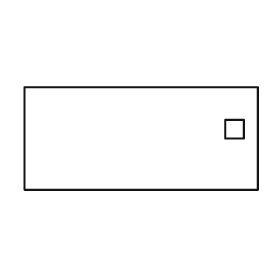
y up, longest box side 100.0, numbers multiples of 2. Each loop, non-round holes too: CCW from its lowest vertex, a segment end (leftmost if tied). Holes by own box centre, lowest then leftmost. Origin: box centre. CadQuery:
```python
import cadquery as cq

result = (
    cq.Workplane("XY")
    .moveTo(-50.0, -22.0)
    .lineTo(50.0, -22.0)
    .lineTo(50.0, 22.0)
    .lineTo(-50.0, 22.0)
    .close()
    .moveTo(36.0, 0.0)
    .lineTo(44.0, 0.0)
    .lineTo(44.0, 8.0)
    .lineTo(36.0, 8.0)
    .close()
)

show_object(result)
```